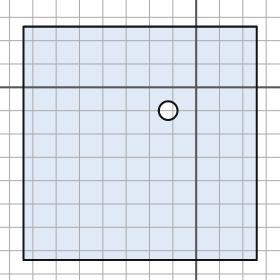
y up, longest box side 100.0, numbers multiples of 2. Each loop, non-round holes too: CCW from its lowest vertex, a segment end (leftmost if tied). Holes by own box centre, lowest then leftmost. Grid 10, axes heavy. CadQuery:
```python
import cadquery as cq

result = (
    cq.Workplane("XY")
    .moveTo(-74.0, -74.0)
    .lineTo(26.0, -74.0)
    .lineTo(26.0, 26.0)
    .lineTo(-74.0, 26.0)
    .close()
    .moveTo(-12.0, -10.0)
    .circle(4.0)
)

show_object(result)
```